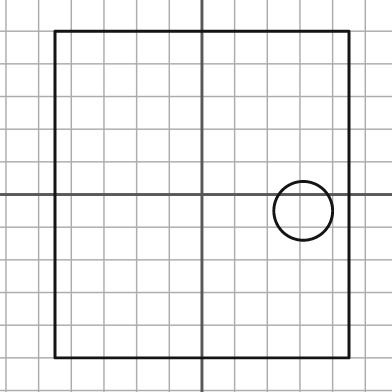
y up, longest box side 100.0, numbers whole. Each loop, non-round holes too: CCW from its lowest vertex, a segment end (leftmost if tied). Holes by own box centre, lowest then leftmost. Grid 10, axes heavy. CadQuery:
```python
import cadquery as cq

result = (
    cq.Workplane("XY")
    .moveTo(-45.0, -50.0)
    .lineTo(45.0, -50.0)
    .lineTo(45.0, 50.0)
    .lineTo(-45.0, 50.0)
    .close()
    .moveTo(31.0, -5.0)
    .circle(9.0)
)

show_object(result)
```